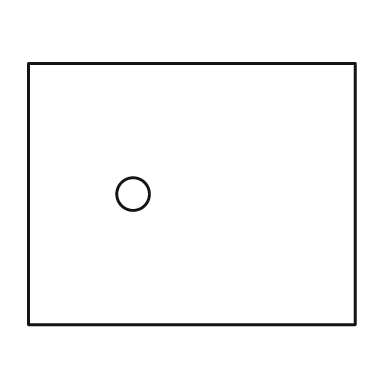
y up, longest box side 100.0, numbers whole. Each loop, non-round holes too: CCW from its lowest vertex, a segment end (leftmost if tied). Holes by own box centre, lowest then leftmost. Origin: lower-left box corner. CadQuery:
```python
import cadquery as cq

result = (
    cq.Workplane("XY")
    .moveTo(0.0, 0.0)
    .lineTo(100.0, 0.0)
    .lineTo(100.0, 80.0)
    .lineTo(0.0, 80.0)
    .close()
    .moveTo(32.0, 40.0)
    .circle(5.0)
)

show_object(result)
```